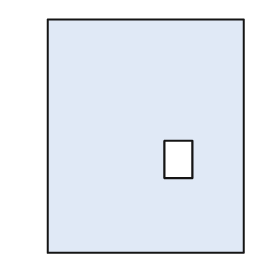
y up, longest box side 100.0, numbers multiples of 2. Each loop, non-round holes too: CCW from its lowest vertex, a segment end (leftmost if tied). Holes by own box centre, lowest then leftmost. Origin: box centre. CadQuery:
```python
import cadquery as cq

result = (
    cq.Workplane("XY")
    .moveTo(-42.0, -50.0)
    .lineTo(42.0, -50.0)
    .lineTo(42.0, 50.0)
    .lineTo(-42.0, 50.0)
    .close()
    .moveTo(8.0, -18.0)
    .lineTo(20.0, -18.0)
    .lineTo(20.0, -2.0)
    .lineTo(8.0, -2.0)
    .close()
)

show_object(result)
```